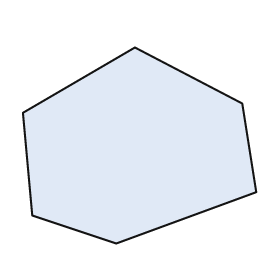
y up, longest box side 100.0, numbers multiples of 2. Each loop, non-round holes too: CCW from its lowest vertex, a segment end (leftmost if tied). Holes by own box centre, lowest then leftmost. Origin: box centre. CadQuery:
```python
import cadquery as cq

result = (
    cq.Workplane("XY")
    .moveTo(-10.0, -42.0)
    .lineTo(50.0, -20.0)
    .lineTo(44.0, 18.0)
    .lineTo(-2.0, 42.0)
    .lineTo(-50.0, 14.0)
    .lineTo(-46.0, -30.0)
    .close()
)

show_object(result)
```